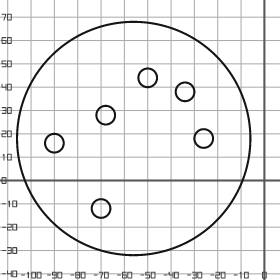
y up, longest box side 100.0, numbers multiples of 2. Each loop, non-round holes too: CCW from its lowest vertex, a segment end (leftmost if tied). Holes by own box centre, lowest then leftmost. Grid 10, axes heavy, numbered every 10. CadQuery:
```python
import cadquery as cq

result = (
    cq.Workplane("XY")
    .moveTo(-56.0, 18.0)
    .circle(50.0)
    .moveTo(-70.0, -12.0)
    .circle(4.0)
    .moveTo(-90.0, 16.0)
    .circle(4.0)
    .moveTo(-26.0, 18.0)
    .circle(4.0)
    .moveTo(-68.0, 28.0)
    .circle(4.0)
    .moveTo(-34.0, 38.0)
    .circle(4.0)
    .moveTo(-50.0, 44.0)
    .circle(4.0)
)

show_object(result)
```